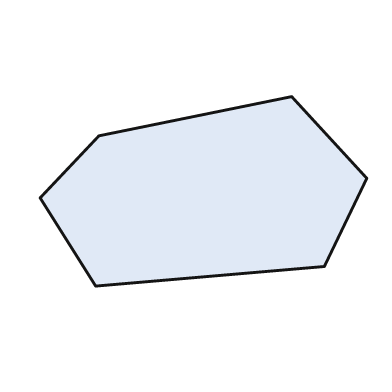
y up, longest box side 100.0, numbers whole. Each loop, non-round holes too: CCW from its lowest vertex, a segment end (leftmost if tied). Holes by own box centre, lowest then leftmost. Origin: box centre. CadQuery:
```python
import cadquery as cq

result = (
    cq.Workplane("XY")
    .moveTo(-33.0, -29.0)
    .lineTo(37.0, -23.0)
    .lineTo(50.0, 4.0)
    .lineTo(27.0, 29.0)
    .lineTo(-32.0, 17.0)
    .lineTo(-50.0, -2.0)
    .close()
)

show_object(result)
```